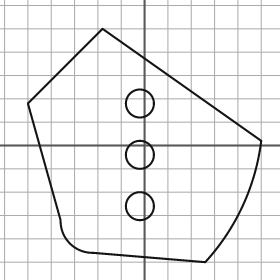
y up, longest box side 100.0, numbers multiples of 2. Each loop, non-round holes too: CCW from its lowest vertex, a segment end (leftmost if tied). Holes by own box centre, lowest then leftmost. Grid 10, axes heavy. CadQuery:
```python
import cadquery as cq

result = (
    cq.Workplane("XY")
    .moveTo(26.0, -50.0)
    .threePointArc((42.0, -26.0), (50.0, 2.0))
    .lineTo(-18.0, 50.0)
    .lineTo(-50.0, 18.0)
    .lineTo(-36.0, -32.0)
    .threePointArc((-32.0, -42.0), (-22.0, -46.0))
    .close()
    .moveTo(-2.0, -26.0)
    .circle(6.0)
    .moveTo(-2.0, -4.0)
    .circle(6.0)
    .moveTo(-2.0, 18.0)
    .circle(6.0)
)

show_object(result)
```